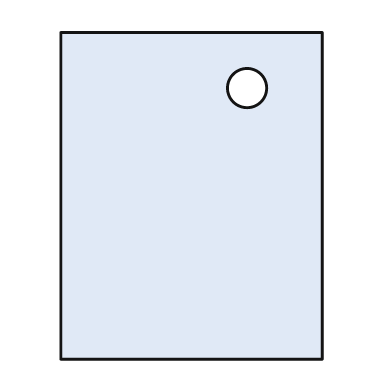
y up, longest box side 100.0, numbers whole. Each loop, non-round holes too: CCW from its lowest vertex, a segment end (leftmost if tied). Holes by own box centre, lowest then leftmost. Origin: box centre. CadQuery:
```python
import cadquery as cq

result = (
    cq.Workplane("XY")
    .moveTo(-40.0, -50.0)
    .lineTo(40.0, -50.0)
    .lineTo(40.0, 50.0)
    .lineTo(-40.0, 50.0)
    .close()
    .moveTo(17.0, 33.0)
    .circle(6.0)
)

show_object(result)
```